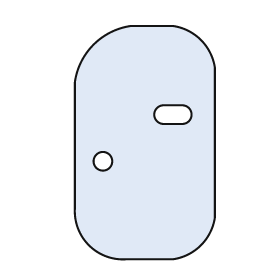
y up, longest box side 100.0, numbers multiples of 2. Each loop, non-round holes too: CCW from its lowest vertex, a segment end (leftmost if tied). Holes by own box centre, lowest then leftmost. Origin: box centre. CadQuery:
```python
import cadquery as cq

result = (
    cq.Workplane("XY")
    .moveTo(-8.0, -50.0)
    .lineTo(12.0, -50.0)
    .threePointArc((24.0, -44.0), (30.0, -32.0))
    .lineTo(30.0, 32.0)
    .threePointArc((24.0, 44.0), (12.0, 50.0))
    .lineTo(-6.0, 50.0)
    .threePointArc((-22.0, 42.0), (-30.0, 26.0))
    .lineTo(-30.0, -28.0)
    .threePointArc((-24.0, -44.0), (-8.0, -50.0))
    .close()
    .moveTo(-18.0, -8.0)
    .circle(4.0)
    .moveTo(8.0, 8.0)
    .lineTo(16.0, 8.0)
    .threePointArc((20.0, 12.0), (16.0, 16.0))
    .lineTo(8.0, 16.0)
    .threePointArc((4.0, 12.0), (8.0, 8.0))
    .close()
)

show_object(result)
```